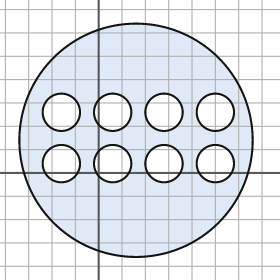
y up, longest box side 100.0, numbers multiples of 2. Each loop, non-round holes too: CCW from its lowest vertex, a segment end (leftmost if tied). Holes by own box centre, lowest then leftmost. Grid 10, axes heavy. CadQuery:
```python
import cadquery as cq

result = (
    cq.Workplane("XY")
    .moveTo(16.0, 14.0)
    .circle(50.0)
    .moveTo(-16.0, 4.0)
    .circle(8.0)
    .moveTo(6.0, 4.0)
    .circle(8.0)
    .moveTo(28.0, 4.0)
    .circle(8.0)
    .moveTo(50.0, 4.0)
    .circle(8.0)
    .moveTo(-16.0, 26.0)
    .circle(8.0)
    .moveTo(6.0, 26.0)
    .circle(8.0)
    .moveTo(28.0, 26.0)
    .circle(8.0)
    .moveTo(50.0, 26.0)
    .circle(8.0)
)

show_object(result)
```